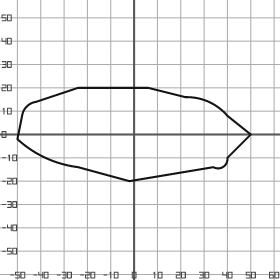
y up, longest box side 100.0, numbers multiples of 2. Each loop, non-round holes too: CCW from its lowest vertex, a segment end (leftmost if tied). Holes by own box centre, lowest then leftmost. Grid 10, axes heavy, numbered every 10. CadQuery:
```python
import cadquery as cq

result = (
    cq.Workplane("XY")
    .moveTo(-2.0, -20.0)
    .lineTo(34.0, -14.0)
    .threePointArc((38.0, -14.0), (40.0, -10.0))
    .lineTo(50.0, 0.0)
    .lineTo(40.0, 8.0)
    .threePointArc((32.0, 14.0), (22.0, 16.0))
    .lineTo(6.0, 20.0)
    .lineTo(-24.0, 20.0)
    .lineTo(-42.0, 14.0)
    .threePointArc((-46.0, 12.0), (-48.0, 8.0))
    .lineTo(-50.0, -2.0)
    .threePointArc((-38.0, -10.0), (-24.0, -14.0))
    .close()
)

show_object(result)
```